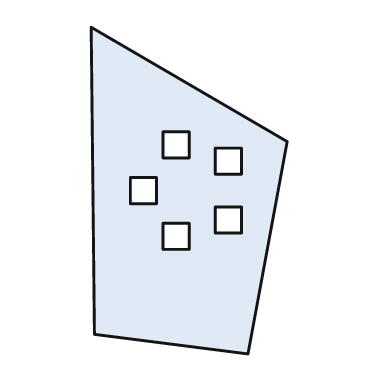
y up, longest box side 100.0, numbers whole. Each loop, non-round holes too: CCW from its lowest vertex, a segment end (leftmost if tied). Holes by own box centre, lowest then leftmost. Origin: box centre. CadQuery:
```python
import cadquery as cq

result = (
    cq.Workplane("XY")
    .moveTo(18.0, -50.0)
    .lineTo(30.0, 15.0)
    .lineTo(-30.0, 50.0)
    .lineTo(-29.0, -44.0)
    .close()
    .moveTo(-8.0, -18.0)
    .lineTo(0.0, -18.0)
    .lineTo(0.0, -10.0)
    .lineTo(-8.0, -10.0)
    .close()
    .moveTo(8.0, -13.0)
    .lineTo(16.0, -13.0)
    .lineTo(16.0, -5.0)
    .lineTo(8.0, -5.0)
    .close()
    .moveTo(-18.0, -4.0)
    .lineTo(-10.0, -4.0)
    .lineTo(-10.0, 4.0)
    .lineTo(-18.0, 4.0)
    .close()
    .moveTo(8.0, 5.0)
    .lineTo(16.0, 5.0)
    .lineTo(16.0, 13.0)
    .lineTo(8.0, 13.0)
    .close()
    .moveTo(-8.0, 10.0)
    .lineTo(0.0, 10.0)
    .lineTo(0.0, 18.0)
    .lineTo(-8.0, 18.0)
    .close()
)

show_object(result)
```